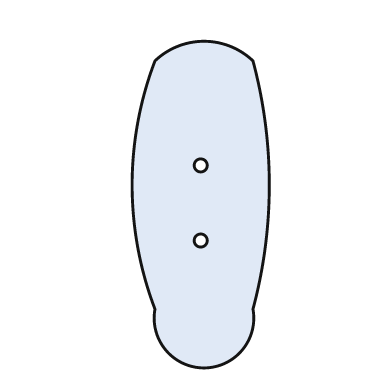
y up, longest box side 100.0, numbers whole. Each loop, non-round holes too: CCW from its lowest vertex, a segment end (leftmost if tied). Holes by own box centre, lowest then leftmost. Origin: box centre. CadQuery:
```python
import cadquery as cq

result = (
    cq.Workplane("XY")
    .moveTo(-14.0, -32.0)
    .threePointArc((1.0, -50.0), (16.0, -32.0))
    .threePointArc((21.0, 6.0), (16.0, 44.0))
    .threePointArc((1.0, 50.0), (-14.0, 44.0))
    .threePointArc((-21.0, 6.0), (-14.0, -32.0))
    .close()
    .moveTo(0.0, -11.0)
    .circle(2.0)
    .moveTo(0.0, 12.0)
    .circle(2.0)
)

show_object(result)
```